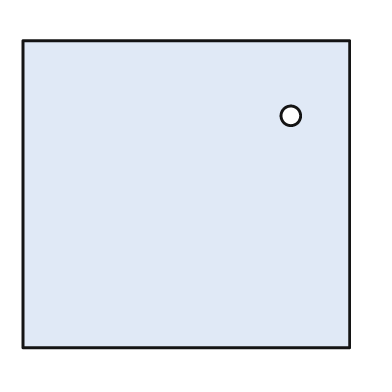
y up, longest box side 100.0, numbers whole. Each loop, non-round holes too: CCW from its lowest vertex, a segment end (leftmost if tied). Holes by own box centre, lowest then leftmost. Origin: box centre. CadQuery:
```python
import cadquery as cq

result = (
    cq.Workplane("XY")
    .moveTo(-50.0, -47.0)
    .lineTo(50.0, -47.0)
    .lineTo(50.0, 47.0)
    .lineTo(-50.0, 47.0)
    .close()
    .moveTo(32.0, 24.0)
    .circle(3.0)
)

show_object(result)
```